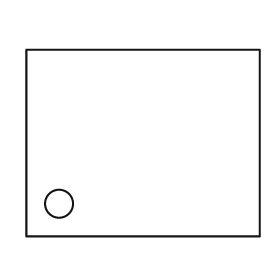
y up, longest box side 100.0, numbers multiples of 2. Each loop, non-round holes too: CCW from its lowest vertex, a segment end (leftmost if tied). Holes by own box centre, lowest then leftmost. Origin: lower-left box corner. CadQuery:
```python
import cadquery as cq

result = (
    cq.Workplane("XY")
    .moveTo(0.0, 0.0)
    .lineTo(100.0, 0.0)
    .lineTo(100.0, 80.0)
    .lineTo(0.0, 80.0)
    .close()
    .moveTo(14.0, 14.0)
    .circle(6.0)
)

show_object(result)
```